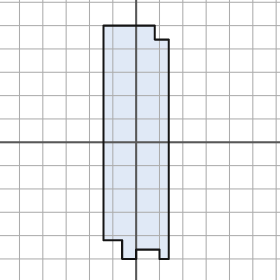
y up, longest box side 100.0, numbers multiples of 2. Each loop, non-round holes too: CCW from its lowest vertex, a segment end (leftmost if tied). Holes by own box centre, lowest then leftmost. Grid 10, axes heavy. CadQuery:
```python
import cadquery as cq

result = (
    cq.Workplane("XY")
    .moveTo(-6.0, -50.0)
    .lineTo(0.0, -50.0)
    .lineTo(0.0, -46.0)
    .lineTo(10.0, -46.0)
    .lineTo(10.0, -50.0)
    .lineTo(14.0, -50.0)
    .lineTo(14.0, 44.0)
    .lineTo(8.0, 44.0)
    .lineTo(8.0, 50.0)
    .lineTo(-14.0, 50.0)
    .lineTo(-14.0, -42.0)
    .lineTo(-6.0, -42.0)
    .close()
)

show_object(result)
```